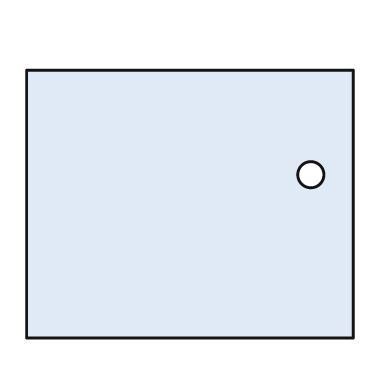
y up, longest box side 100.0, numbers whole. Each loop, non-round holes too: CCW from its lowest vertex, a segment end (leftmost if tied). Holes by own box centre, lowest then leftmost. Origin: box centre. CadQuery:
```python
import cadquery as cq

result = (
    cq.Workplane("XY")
    .moveTo(-50.0, -41.0)
    .lineTo(50.0, -41.0)
    .lineTo(50.0, 41.0)
    .lineTo(-50.0, 41.0)
    .close()
    .moveTo(37.0, 9.0)
    .circle(4.0)
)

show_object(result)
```